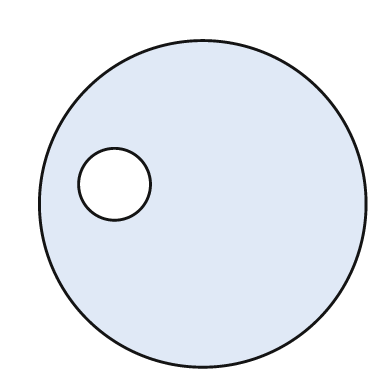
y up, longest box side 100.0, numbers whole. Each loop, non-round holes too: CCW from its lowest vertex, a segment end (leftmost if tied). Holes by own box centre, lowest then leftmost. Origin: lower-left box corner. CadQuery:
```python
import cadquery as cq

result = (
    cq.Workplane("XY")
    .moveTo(50.0, 50.0)
    .circle(50.0)
    .moveTo(23.0, 56.0)
    .circle(11.0)
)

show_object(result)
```